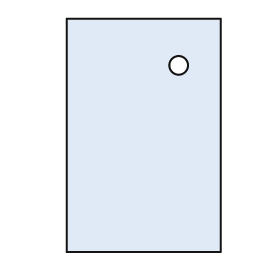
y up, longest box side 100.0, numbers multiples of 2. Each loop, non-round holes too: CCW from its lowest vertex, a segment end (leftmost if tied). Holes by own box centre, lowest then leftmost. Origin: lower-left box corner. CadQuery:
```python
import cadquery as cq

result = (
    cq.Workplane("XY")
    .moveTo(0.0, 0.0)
    .lineTo(66.0, 0.0)
    .lineTo(66.0, 100.0)
    .lineTo(0.0, 100.0)
    .close()
    .moveTo(48.0, 80.0)
    .circle(4.0)
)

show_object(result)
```